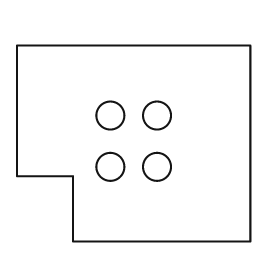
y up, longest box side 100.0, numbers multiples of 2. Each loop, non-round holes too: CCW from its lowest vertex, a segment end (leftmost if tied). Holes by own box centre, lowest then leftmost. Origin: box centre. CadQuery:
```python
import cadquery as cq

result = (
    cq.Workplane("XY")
    .moveTo(-26.0, -42.0)
    .lineTo(50.0, -42.0)
    .lineTo(50.0, 42.0)
    .lineTo(-50.0, 42.0)
    .lineTo(-50.0, -14.0)
    .lineTo(-26.0, -14.0)
    .close()
    .moveTo(-10.0, -10.0)
    .circle(6.0)
    .moveTo(10.0, -10.0)
    .circle(6.0)
    .moveTo(-10.0, 12.0)
    .circle(6.0)
    .moveTo(10.0, 12.0)
    .circle(6.0)
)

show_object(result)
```